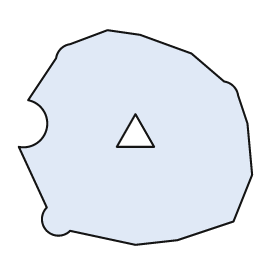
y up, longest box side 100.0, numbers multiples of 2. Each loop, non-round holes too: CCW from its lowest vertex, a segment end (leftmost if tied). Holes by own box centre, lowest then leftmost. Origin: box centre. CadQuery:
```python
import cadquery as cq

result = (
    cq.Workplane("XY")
    .moveTo(0.0, -46.0)
    .lineTo(18.0, -44.0)
    .lineTo(42.0, -36.0)
    .lineTo(50.0, -16.0)
    .lineTo(48.0, 6.0)
    .lineTo(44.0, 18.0)
    .threePointArc((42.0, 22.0), (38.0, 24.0))
    .lineTo(24.0, 36.0)
    .lineTo(2.0, 44.0)
    .lineTo(-12.0, 46.0)
    .lineTo(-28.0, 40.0)
    .threePointArc((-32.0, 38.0), (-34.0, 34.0))
    .lineTo(-46.0, 16.0)
    .threePointArc((-38.0, 4.0), (-50.0, -4.0))
    .lineTo(-38.0, -30.0)
    .threePointArc((-38.0, -40.0), (-28.0, -40.0))
    .close()
    .moveTo(-8.0, -4.0)
    .lineTo(8.0, -4.0)
    .lineTo(0.0, 10.0)
    .close()
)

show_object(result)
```